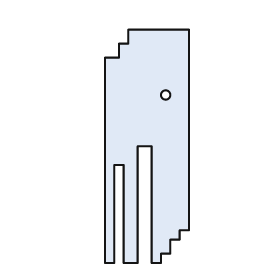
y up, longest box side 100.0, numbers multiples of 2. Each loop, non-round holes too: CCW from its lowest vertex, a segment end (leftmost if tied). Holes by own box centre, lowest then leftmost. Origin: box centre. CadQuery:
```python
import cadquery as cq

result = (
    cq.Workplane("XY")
    .moveTo(-18.0, -50.0)
    .lineTo(-14.0, -50.0)
    .lineTo(-14.0, -8.0)
    .lineTo(-10.0, -8.0)
    .lineTo(-10.0, -50.0)
    .lineTo(-4.0, -50.0)
    .lineTo(-4.0, 0.0)
    .lineTo(2.0, 0.0)
    .lineTo(2.0, -50.0)
    .lineTo(6.0, -50.0)
    .lineTo(6.0, -46.0)
    .lineTo(10.0, -46.0)
    .lineTo(10.0, -40.0)
    .lineTo(14.0, -40.0)
    .lineTo(14.0, -36.0)
    .lineTo(18.0, -36.0)
    .lineTo(18.0, 50.0)
    .lineTo(-8.0, 50.0)
    .lineTo(-8.0, 44.0)
    .lineTo(-12.0, 44.0)
    .lineTo(-12.0, 38.0)
    .lineTo(-18.0, 38.0)
    .close()
    .moveTo(8.0, 22.0)
    .circle(2.0)
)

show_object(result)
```